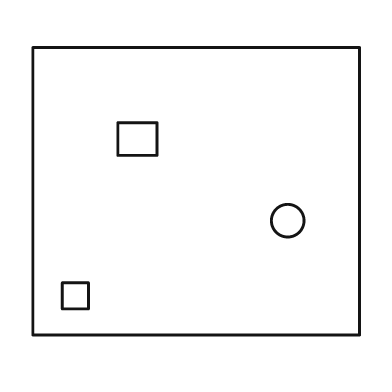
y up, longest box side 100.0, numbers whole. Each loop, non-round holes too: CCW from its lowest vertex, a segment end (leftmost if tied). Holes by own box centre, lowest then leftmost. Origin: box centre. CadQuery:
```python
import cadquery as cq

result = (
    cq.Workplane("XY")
    .moveTo(-50.0, -44.0)
    .lineTo(50.0, -44.0)
    .lineTo(50.0, 44.0)
    .lineTo(-50.0, 44.0)
    .close()
    .moveTo(-41.0, -36.0)
    .lineTo(-33.0, -36.0)
    .lineTo(-33.0, -28.0)
    .lineTo(-41.0, -28.0)
    .close()
    .moveTo(28.0, -9.0)
    .circle(5.0)
    .moveTo(-24.0, 11.0)
    .lineTo(-12.0, 11.0)
    .lineTo(-12.0, 21.0)
    .lineTo(-24.0, 21.0)
    .close()
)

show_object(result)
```